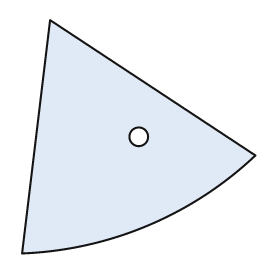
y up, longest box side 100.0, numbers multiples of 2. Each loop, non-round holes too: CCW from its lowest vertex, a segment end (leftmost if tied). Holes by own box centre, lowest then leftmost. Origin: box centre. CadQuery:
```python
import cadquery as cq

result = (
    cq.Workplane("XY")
    .moveTo(-50.0, -50.0)
    .threePointArc((4.0, -38.0), (50.0, -8.0))
    .lineTo(-38.0, 50.0)
    .close()
    .moveTo(0.0, 0.0)
    .circle(4.0)
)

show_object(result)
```